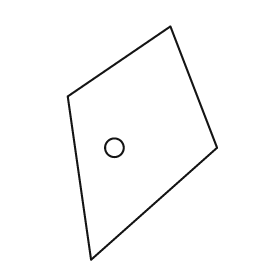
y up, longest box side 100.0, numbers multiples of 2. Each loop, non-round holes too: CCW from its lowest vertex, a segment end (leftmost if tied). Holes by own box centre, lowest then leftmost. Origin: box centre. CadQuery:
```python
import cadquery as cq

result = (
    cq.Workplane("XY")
    .moveTo(-22.0, -50.0)
    .lineTo(32.0, -2.0)
    .lineTo(12.0, 50.0)
    .lineTo(-32.0, 20.0)
    .close()
    .moveTo(-12.0, -2.0)
    .circle(4.0)
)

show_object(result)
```